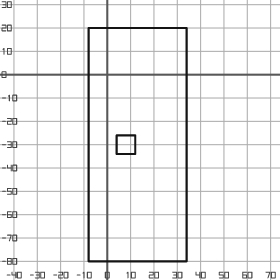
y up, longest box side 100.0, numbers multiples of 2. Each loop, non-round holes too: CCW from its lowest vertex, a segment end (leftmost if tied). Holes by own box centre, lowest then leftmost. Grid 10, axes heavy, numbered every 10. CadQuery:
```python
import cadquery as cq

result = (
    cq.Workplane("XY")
    .moveTo(-8.0, -80.0)
    .lineTo(34.0, -80.0)
    .lineTo(34.0, 20.0)
    .lineTo(-8.0, 20.0)
    .close()
    .moveTo(4.0, -34.0)
    .lineTo(12.0, -34.0)
    .lineTo(12.0, -26.0)
    .lineTo(4.0, -26.0)
    .close()
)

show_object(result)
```